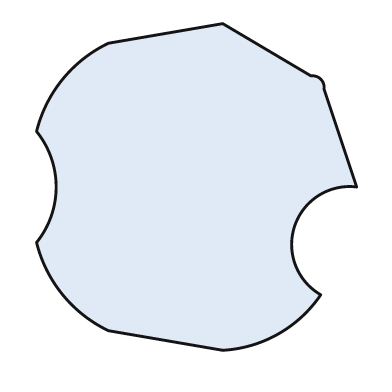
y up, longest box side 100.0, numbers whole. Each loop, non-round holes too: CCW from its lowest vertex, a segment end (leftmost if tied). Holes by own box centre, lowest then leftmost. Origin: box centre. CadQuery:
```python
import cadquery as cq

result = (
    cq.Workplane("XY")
    .moveTo(8.0, -50.0)
    .threePointArc((25.0, -45.0), (38.0, -33.0))
    .threePointArc((30.0, -12.0), (49.0, 0.0))
    .lineTo(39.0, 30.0)
    .threePointArc((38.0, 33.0), (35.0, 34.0))
    .lineTo(8.0, 50.0)
    .lineTo(-27.0, 44.0)
    .threePointArc((-41.0, 33.0), (-49.0, 17.0))
    .threePointArc((-43.0, 0.0), (-49.0, -17.0))
    .threePointArc((-41.0, -33.0), (-27.0, -44.0))
    .close()
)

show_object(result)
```